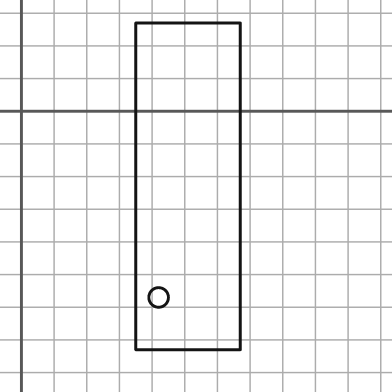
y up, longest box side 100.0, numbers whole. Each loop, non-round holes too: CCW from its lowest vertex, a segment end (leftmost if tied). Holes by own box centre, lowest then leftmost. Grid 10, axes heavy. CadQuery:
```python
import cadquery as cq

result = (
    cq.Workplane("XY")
    .moveTo(35.0, -73.0)
    .lineTo(67.0, -73.0)
    .lineTo(67.0, 27.0)
    .lineTo(35.0, 27.0)
    .close()
    .moveTo(42.0, -57.0)
    .circle(3.0)
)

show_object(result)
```